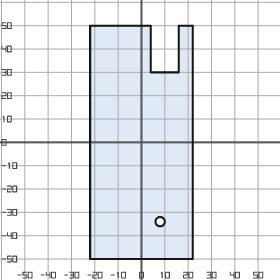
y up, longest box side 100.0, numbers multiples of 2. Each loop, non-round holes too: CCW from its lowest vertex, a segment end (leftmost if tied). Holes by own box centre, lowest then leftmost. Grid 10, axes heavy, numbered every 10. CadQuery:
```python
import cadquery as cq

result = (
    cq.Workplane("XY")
    .moveTo(-22.0, -50.0)
    .lineTo(22.0, -50.0)
    .lineTo(22.0, 50.0)
    .lineTo(16.0, 50.0)
    .lineTo(16.0, 30.0)
    .lineTo(4.0, 30.0)
    .lineTo(4.0, 50.0)
    .lineTo(-22.0, 50.0)
    .close()
    .moveTo(8.0, -34.0)
    .circle(2.0)
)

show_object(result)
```